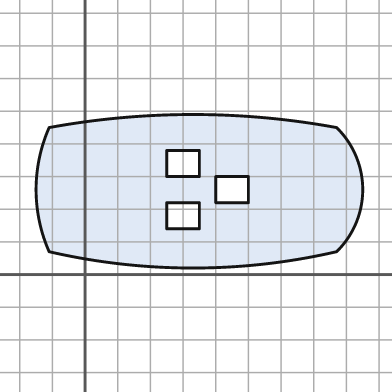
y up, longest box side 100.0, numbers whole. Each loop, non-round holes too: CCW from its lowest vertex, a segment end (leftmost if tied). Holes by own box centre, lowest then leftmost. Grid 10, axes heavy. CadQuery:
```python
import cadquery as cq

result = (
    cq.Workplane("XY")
    .moveTo(-11.0, 7.0)
    .threePointArc((33.0, 2.0), (77.0, 7.0))
    .threePointArc((85.0, 26.0), (77.0, 45.0))
    .threePointArc((33.0, 49.0), (-11.0, 45.0))
    .threePointArc((-15.0, 26.0), (-11.0, 7.0))
    .close()
    .moveTo(25.0, 14.0)
    .lineTo(35.0, 14.0)
    .lineTo(35.0, 22.0)
    .lineTo(25.0, 22.0)
    .close()
    .moveTo(40.0, 22.0)
    .lineTo(50.0, 22.0)
    .lineTo(50.0, 30.0)
    .lineTo(40.0, 30.0)
    .close()
    .moveTo(25.0, 30.0)
    .lineTo(35.0, 30.0)
    .lineTo(35.0, 38.0)
    .lineTo(25.0, 38.0)
    .close()
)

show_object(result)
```